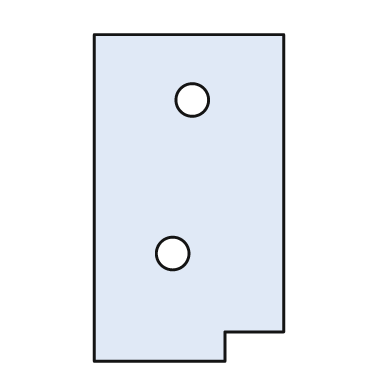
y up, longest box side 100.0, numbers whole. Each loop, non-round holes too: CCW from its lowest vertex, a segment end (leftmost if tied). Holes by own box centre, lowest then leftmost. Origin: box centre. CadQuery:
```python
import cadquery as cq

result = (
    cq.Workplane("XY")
    .moveTo(-29.0, -50.0)
    .lineTo(11.0, -50.0)
    .lineTo(11.0, -41.0)
    .lineTo(29.0, -41.0)
    .lineTo(29.0, 50.0)
    .lineTo(-29.0, 50.0)
    .close()
    .moveTo(-5.0, -17.0)
    .circle(5.0)
    .moveTo(1.0, 30.0)
    .circle(5.0)
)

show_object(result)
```